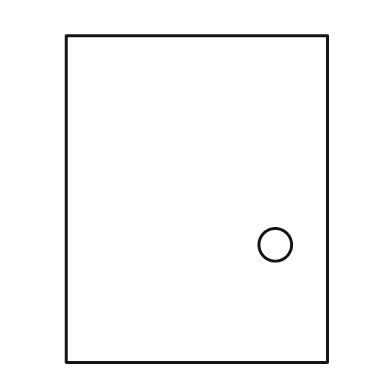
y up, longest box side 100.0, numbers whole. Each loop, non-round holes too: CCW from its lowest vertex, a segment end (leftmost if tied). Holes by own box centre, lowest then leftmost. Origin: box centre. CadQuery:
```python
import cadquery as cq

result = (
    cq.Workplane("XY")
    .moveTo(-40.0, -50.0)
    .lineTo(40.0, -50.0)
    .lineTo(40.0, 50.0)
    .lineTo(-40.0, 50.0)
    .close()
    .moveTo(24.0, -14.0)
    .circle(5.0)
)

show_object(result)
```